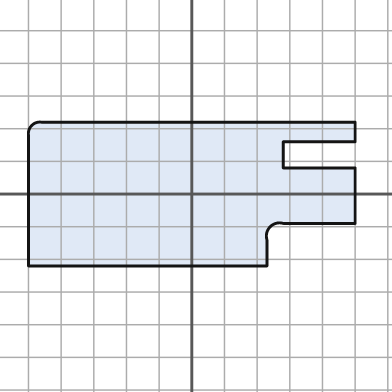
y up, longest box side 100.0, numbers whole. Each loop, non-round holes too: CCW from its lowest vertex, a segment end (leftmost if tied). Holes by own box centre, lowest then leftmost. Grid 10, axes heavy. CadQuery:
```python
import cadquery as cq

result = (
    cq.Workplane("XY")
    .moveTo(-50.0, -22.0)
    .lineTo(23.0, -22.0)
    .lineTo(23.0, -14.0)
    .threePointArc((24.0, -10.0), (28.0, -9.0))
    .lineTo(50.0, -9.0)
    .lineTo(50.0, 8.0)
    .lineTo(28.0, 8.0)
    .lineTo(28.0, 16.0)
    .lineTo(50.0, 16.0)
    .lineTo(50.0, 22.0)
    .lineTo(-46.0, 22.0)
    .threePointArc((-49.0, 21.0), (-50.0, 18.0))
    .close()
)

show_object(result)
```